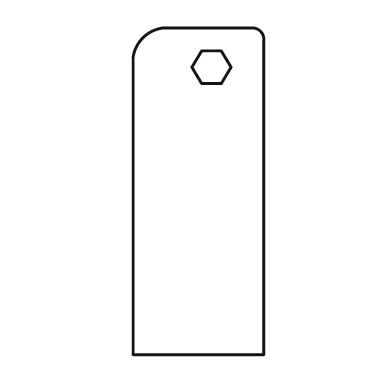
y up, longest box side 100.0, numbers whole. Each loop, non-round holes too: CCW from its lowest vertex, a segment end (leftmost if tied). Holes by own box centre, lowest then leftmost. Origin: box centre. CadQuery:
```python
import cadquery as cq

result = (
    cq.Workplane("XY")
    .moveTo(-20.0, -50.0)
    .lineTo(20.0, -50.0)
    .lineTo(20.0, 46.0)
    .threePointArc((19.0, 49.0), (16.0, 50.0))
    .lineTo(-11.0, 50.0)
    .threePointArc((-17.0, 47.0), (-20.0, 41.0))
    .close()
    .moveTo(1.0, 33.0)
    .lineTo(7.0, 33.0)
    .lineTo(10.0, 38.0)
    .lineTo(7.0, 43.0)
    .lineTo(1.0, 43.0)
    .lineTo(-2.0, 38.0)
    .close()
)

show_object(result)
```